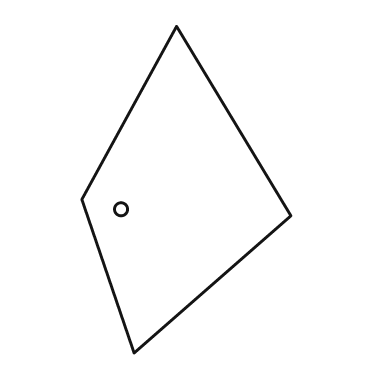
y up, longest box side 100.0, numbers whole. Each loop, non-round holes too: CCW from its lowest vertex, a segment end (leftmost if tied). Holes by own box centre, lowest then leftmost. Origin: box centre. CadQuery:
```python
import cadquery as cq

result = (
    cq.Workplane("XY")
    .moveTo(-16.0, -50.0)
    .lineTo(32.0, -8.0)
    .lineTo(-3.0, 50.0)
    .lineTo(-32.0, -3.0)
    .close()
    .moveTo(-20.0, -6.0)
    .circle(2.0)
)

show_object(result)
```